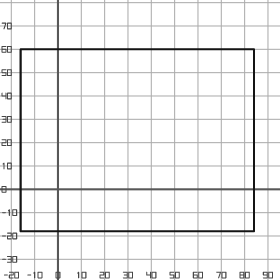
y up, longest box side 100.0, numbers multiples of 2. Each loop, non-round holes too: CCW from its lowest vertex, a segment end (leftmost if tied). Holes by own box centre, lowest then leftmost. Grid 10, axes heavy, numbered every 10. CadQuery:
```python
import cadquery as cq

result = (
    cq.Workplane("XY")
    .moveTo(-16.0, -18.0)
    .lineTo(84.0, -18.0)
    .lineTo(84.0, 60.0)
    .lineTo(-16.0, 60.0)
    .close()
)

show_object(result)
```